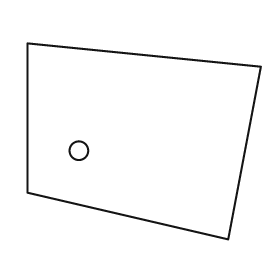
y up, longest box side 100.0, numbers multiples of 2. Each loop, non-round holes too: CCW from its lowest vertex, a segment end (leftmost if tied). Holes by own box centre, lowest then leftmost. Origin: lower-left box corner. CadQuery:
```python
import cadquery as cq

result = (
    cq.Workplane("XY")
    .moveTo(86.0, 0.0)
    .lineTo(100.0, 74.0)
    .lineTo(0.0, 84.0)
    .lineTo(0.0, 20.0)
    .close()
    .moveTo(22.0, 38.0)
    .circle(4.0)
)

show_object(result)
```